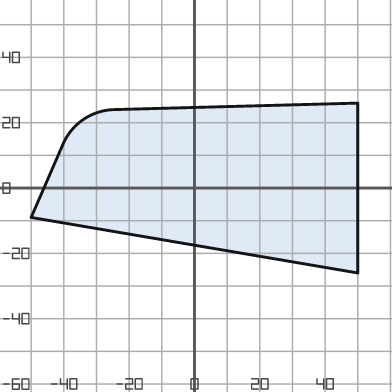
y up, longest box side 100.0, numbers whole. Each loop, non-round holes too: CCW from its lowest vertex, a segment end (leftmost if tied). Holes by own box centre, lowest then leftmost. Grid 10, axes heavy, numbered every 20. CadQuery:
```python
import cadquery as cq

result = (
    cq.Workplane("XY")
    .moveTo(50.0, -26.0)
    .lineTo(50.0, 26.0)
    .lineTo(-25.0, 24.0)
    .threePointArc((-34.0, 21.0), (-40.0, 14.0))
    .lineTo(-50.0, -9.0)
    .close()
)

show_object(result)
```